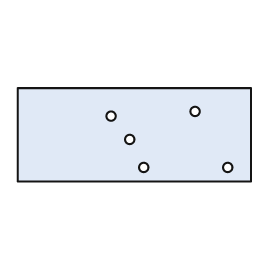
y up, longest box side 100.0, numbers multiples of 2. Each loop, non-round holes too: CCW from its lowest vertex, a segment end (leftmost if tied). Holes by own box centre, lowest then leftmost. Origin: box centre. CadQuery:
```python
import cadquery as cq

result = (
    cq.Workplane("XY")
    .moveTo(-50.0, -20.0)
    .lineTo(50.0, -20.0)
    .lineTo(50.0, 20.0)
    .lineTo(-50.0, 20.0)
    .close()
    .moveTo(4.0, -14.0)
    .circle(2.0)
    .moveTo(40.0, -14.0)
    .circle(2.0)
    .moveTo(-2.0, -2.0)
    .circle(2.0)
    .moveTo(-10.0, 8.0)
    .circle(2.0)
    .moveTo(26.0, 10.0)
    .circle(2.0)
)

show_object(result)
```